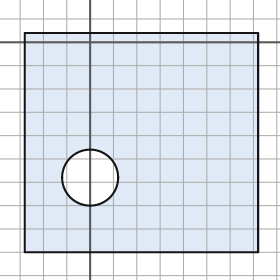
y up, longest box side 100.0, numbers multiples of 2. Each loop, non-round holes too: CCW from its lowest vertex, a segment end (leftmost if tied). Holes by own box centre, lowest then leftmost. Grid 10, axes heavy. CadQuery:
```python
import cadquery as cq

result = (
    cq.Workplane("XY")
    .moveTo(-28.0, -90.0)
    .lineTo(72.0, -90.0)
    .lineTo(72.0, 4.0)
    .lineTo(-28.0, 4.0)
    .close()
    .moveTo(0.0, -58.0)
    .circle(12.0)
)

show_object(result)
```